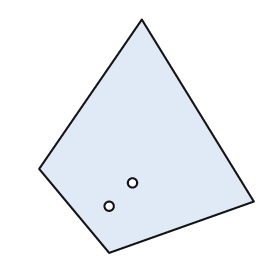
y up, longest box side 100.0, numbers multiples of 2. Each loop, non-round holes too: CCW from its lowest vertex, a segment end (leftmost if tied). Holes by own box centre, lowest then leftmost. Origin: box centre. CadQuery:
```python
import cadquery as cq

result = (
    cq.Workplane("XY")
    .moveTo(-16.0, -50.0)
    .lineTo(46.0, -28.0)
    .lineTo(-2.0, 50.0)
    .lineTo(-46.0, -14.0)
    .close()
    .moveTo(-16.0, -30.0)
    .circle(2.0)
    .moveTo(-6.0, -20.0)
    .circle(2.0)
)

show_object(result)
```